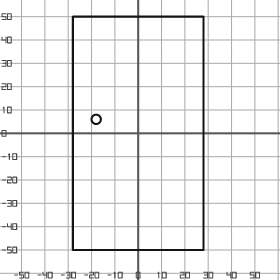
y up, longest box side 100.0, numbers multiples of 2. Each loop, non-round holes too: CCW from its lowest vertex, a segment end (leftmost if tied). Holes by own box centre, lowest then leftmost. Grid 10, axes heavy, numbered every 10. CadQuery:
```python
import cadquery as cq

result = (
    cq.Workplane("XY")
    .moveTo(-28.0, -50.0)
    .lineTo(28.0, -50.0)
    .lineTo(28.0, 50.0)
    .lineTo(-28.0, 50.0)
    .close()
    .moveTo(-18.0, 6.0)
    .circle(2.0)
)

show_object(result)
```